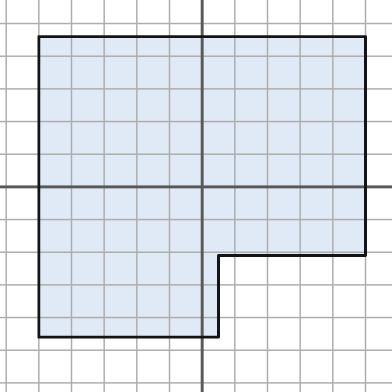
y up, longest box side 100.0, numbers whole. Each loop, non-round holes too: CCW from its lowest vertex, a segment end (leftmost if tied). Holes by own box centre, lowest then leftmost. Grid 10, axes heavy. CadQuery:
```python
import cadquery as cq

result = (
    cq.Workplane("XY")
    .moveTo(-50.0, -46.0)
    .lineTo(5.0, -46.0)
    .lineTo(5.0, -21.0)
    .lineTo(50.0, -21.0)
    .lineTo(50.0, 46.0)
    .lineTo(-50.0, 46.0)
    .close()
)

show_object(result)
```